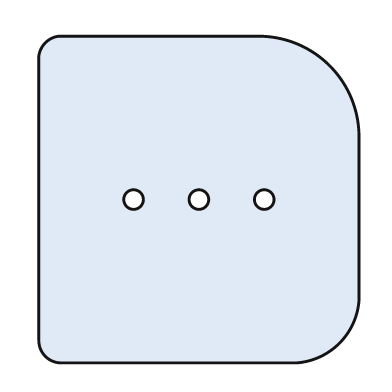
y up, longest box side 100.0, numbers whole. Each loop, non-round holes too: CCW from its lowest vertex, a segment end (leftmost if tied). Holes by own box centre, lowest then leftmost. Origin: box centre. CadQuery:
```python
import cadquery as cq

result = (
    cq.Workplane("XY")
    .moveTo(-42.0, -50.0)
    .lineTo(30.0, -50.0)
    .threePointArc((43.0, -44.0), (49.0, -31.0))
    .lineTo(49.0, 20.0)
    .threePointArc((40.0, 41.0), (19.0, 50.0))
    .lineTo(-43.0, 50.0)
    .threePointArc((-47.0, 48.0), (-49.0, 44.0))
    .lineTo(-49.0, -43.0)
    .threePointArc((-47.0, -48.0), (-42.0, -50.0))
    .close()
    .moveTo(-20.0, 0.0)
    .circle(3.0)
    .moveTo(0.0, 0.0)
    .circle(3.0)
    .moveTo(20.0, 0.0)
    .circle(3.0)
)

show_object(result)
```